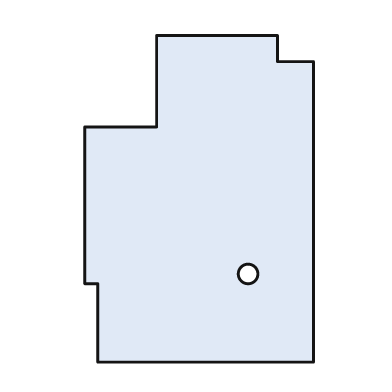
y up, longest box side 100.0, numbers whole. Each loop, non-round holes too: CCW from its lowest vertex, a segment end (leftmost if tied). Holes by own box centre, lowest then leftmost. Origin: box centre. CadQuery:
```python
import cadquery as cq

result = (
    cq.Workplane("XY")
    .moveTo(-31.0, -50.0)
    .lineTo(35.0, -50.0)
    .lineTo(35.0, 42.0)
    .lineTo(24.0, 42.0)
    .lineTo(24.0, 50.0)
    .lineTo(-13.0, 50.0)
    .lineTo(-13.0, 22.0)
    .lineTo(-35.0, 22.0)
    .lineTo(-35.0, -26.0)
    .lineTo(-31.0, -26.0)
    .close()
    .moveTo(15.0, -23.0)
    .circle(3.0)
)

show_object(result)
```